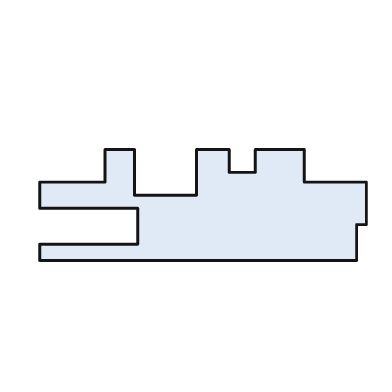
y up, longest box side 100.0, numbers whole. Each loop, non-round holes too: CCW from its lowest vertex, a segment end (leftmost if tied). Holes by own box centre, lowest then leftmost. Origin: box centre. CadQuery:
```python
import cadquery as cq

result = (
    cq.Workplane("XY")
    .moveTo(-50.0, -17.0)
    .lineTo(47.0, -17.0)
    .lineTo(47.0, -6.0)
    .lineTo(50.0, -6.0)
    .lineTo(50.0, 7.0)
    .lineTo(31.0, 7.0)
    .lineTo(31.0, 17.0)
    .lineTo(16.0, 17.0)
    .lineTo(16.0, 10.0)
    .lineTo(8.0, 10.0)
    .lineTo(8.0, 17.0)
    .lineTo(-2.0, 17.0)
    .lineTo(-2.0, 3.0)
    .lineTo(-21.0, 3.0)
    .lineTo(-21.0, 17.0)
    .lineTo(-30.0, 17.0)
    .lineTo(-30.0, 7.0)
    .lineTo(-50.0, 7.0)
    .lineTo(-50.0, -1.0)
    .lineTo(-20.0, -1.0)
    .lineTo(-20.0, -12.0)
    .lineTo(-50.0, -12.0)
    .close()
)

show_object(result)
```